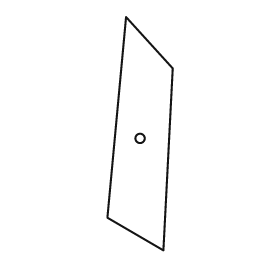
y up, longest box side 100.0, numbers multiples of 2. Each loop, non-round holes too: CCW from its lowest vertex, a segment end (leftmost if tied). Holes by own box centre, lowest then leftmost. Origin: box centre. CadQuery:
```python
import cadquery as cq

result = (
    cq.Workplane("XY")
    .moveTo(10.0, -50.0)
    .lineTo(14.0, 28.0)
    .lineTo(-6.0, 50.0)
    .lineTo(-14.0, -36.0)
    .close()
    .moveTo(0.0, -2.0)
    .circle(2.0)
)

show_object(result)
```